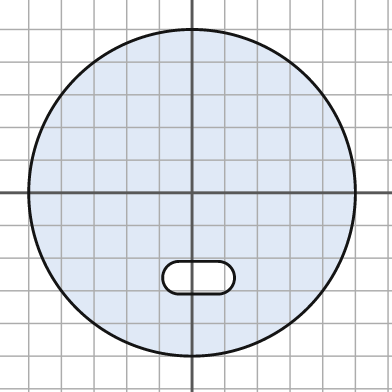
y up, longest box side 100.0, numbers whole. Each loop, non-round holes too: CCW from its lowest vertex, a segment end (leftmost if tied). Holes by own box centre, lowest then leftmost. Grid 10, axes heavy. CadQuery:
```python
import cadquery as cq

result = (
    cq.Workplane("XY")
    .moveTo(0.0, 0.0)
    .circle(50.0)
    .moveTo(-4.0, -31.0)
    .lineTo(8.0, -31.0)
    .threePointArc((13.0, -26.0), (8.0, -21.0))
    .lineTo(-4.0, -21.0)
    .threePointArc((-9.0, -26.0), (-4.0, -31.0))
    .close()
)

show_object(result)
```